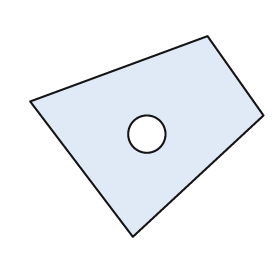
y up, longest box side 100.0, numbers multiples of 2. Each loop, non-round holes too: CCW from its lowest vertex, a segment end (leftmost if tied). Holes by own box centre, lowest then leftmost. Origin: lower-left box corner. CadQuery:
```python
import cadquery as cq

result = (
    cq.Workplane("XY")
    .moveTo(44.0, 0.0)
    .lineTo(100.0, 52.0)
    .lineTo(76.0, 86.0)
    .lineTo(0.0, 58.0)
    .close()
    .moveTo(50.0, 44.0)
    .circle(8.0)
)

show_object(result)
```